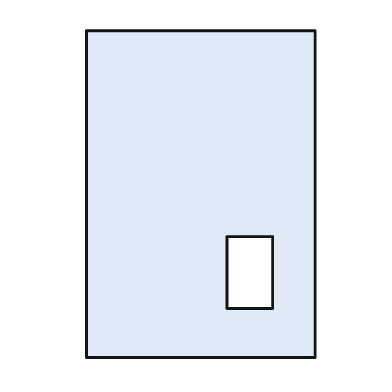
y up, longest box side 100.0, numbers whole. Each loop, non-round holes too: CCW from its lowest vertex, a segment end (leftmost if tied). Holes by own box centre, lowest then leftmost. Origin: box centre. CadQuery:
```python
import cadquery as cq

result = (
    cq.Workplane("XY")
    .moveTo(-35.0, -50.0)
    .lineTo(35.0, -50.0)
    .lineTo(35.0, 50.0)
    .lineTo(-35.0, 50.0)
    .close()
    .moveTo(8.0, -35.0)
    .lineTo(22.0, -35.0)
    .lineTo(22.0, -13.0)
    .lineTo(8.0, -13.0)
    .close()
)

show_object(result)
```